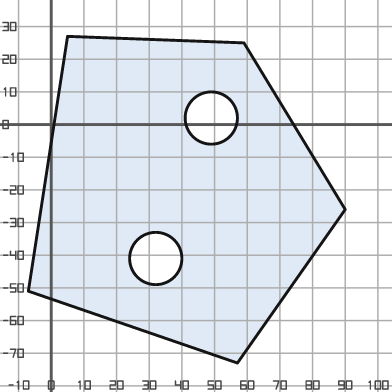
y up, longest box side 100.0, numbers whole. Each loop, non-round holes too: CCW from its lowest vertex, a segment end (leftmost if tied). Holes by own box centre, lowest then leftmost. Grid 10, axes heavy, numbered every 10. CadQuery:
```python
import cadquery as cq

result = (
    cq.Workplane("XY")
    .moveTo(57.0, -73.0)
    .lineTo(90.0, -26.0)
    .lineTo(59.0, 25.0)
    .lineTo(5.0, 27.0)
    .lineTo(-7.0, -51.0)
    .close()
    .moveTo(32.0, -41.0)
    .circle(8.0)
    .moveTo(49.0, 2.0)
    .circle(8.0)
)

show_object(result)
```